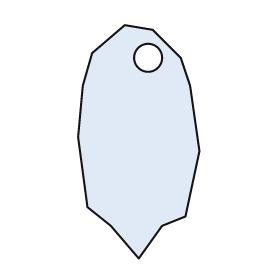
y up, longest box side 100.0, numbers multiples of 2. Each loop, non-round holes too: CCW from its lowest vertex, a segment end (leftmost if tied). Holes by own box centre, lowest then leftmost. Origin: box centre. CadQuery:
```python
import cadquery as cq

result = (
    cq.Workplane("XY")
    .moveTo(0.0, -50.0)
    .lineTo(10.0, -36.0)
    .lineTo(20.0, -32.0)
    .lineTo(26.0, -4.0)
    .lineTo(22.0, 24.0)
    .lineTo(18.0, 36.0)
    .lineTo(6.0, 48.0)
    .lineTo(-6.0, 50.0)
    .lineTo(-20.0, 38.0)
    .lineTo(-24.0, 24.0)
    .lineTo(-26.0, 2.0)
    .lineTo(-22.0, -28.0)
    .lineTo(-12.0, -36.0)
    .close()
    .moveTo(4.0, 36.0)
    .circle(6.0)
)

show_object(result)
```